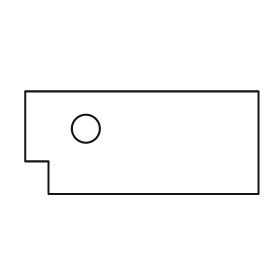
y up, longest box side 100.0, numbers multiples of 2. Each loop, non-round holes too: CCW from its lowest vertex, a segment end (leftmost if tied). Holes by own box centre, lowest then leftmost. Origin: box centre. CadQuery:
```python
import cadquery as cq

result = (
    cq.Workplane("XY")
    .moveTo(-40.0, -22.0)
    .lineTo(50.0, -22.0)
    .lineTo(50.0, 22.0)
    .lineTo(-50.0, 22.0)
    .lineTo(-50.0, -8.0)
    .lineTo(-40.0, -8.0)
    .close()
    .moveTo(-24.0, 6.0)
    .circle(6.0)
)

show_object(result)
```